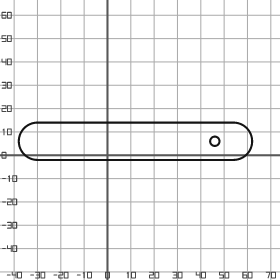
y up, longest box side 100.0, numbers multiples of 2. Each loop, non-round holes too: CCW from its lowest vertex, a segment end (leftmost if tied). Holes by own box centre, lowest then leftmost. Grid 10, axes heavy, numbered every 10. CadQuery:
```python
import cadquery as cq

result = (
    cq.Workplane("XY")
    .moveTo(-30.0, -2.0)
    .lineTo(54.0, -2.0)
    .threePointArc((62.0, 6.0), (54.0, 14.0))
    .lineTo(-30.0, 14.0)
    .threePointArc((-38.0, 6.0), (-30.0, -2.0))
    .close()
    .moveTo(46.0, 6.0)
    .circle(2.0)
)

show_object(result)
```